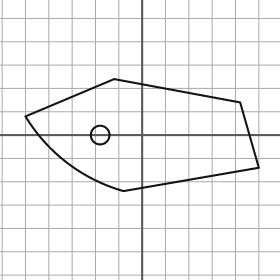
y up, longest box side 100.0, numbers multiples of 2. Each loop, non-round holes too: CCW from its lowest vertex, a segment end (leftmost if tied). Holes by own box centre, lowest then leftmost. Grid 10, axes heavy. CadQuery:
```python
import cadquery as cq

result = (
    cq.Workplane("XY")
    .moveTo(-8.0, -24.0)
    .lineTo(50.0, -14.0)
    .lineTo(42.0, 14.0)
    .lineTo(-12.0, 24.0)
    .lineTo(-50.0, 8.0)
    .threePointArc((-32.0, -12.0), (-8.0, -24.0))
    .close()
    .moveTo(-18.0, 0.0)
    .circle(4.0)
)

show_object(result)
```